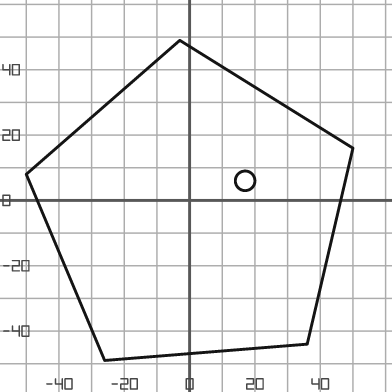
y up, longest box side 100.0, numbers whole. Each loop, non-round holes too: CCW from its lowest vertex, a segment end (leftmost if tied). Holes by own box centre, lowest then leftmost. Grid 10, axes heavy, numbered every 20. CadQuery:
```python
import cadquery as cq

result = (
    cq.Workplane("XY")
    .moveTo(-26.0, -49.0)
    .lineTo(36.0, -44.0)
    .lineTo(50.0, 16.0)
    .lineTo(-3.0, 49.0)
    .lineTo(-50.0, 8.0)
    .close()
    .moveTo(17.0, 6.0)
    .circle(3.0)
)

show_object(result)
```